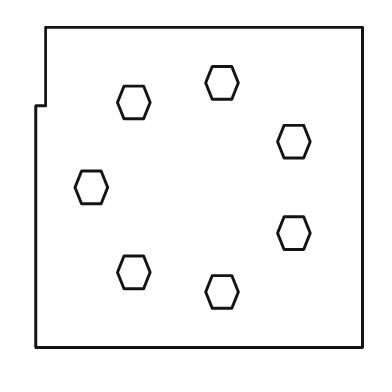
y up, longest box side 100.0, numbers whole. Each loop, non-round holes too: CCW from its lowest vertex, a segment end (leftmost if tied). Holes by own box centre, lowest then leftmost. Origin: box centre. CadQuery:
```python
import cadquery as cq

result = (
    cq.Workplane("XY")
    .moveTo(-50.0, -49.0)
    .lineTo(50.0, -49.0)
    .lineTo(50.0, 49.0)
    .lineTo(-47.0, 49.0)
    .lineTo(-47.0, 25.0)
    .lineTo(-50.0, 25.0)
    .close()
    .moveTo(4.0, -37.0)
    .lineTo(10.0, -37.0)
    .lineTo(12.0, -32.0)
    .lineTo(10.0, -27.0)
    .lineTo(4.0, -27.0)
    .lineTo(2.0, -32.0)
    .close()
    .moveTo(-23.0, -31.0)
    .lineTo(-17.0, -31.0)
    .lineTo(-15.0, -26.0)
    .lineTo(-17.0, -21.0)
    .lineTo(-23.0, -21.0)
    .lineTo(-25.0, -26.0)
    .close()
    .moveTo(26.0, -19.0)
    .lineTo(32.0, -19.0)
    .lineTo(34.0, -14.0)
    .lineTo(32.0, -9.0)
    .lineTo(26.0, -9.0)
    .lineTo(24.0, -14.0)
    .close()
    .moveTo(-36.0, -5.0)
    .lineTo(-30.0, -5.0)
    .lineTo(-28.0, 0.0)
    .lineTo(-30.0, 5.0)
    .lineTo(-36.0, 5.0)
    .lineTo(-38.0, 0.0)
    .close()
    .moveTo(26.0, 9.0)
    .lineTo(32.0, 9.0)
    .lineTo(34.0, 14.0)
    .lineTo(32.0, 19.0)
    .lineTo(26.0, 19.0)
    .lineTo(24.0, 14.0)
    .close()
    .moveTo(-23.0, 21.0)
    .lineTo(-17.0, 21.0)
    .lineTo(-15.0, 26.0)
    .lineTo(-17.0, 31.0)
    .lineTo(-23.0, 31.0)
    .lineTo(-25.0, 26.0)
    .close()
    .moveTo(4.0, 27.0)
    .lineTo(10.0, 27.0)
    .lineTo(12.0, 32.0)
    .lineTo(10.0, 37.0)
    .lineTo(4.0, 37.0)
    .lineTo(2.0, 32.0)
    .close()
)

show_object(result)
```